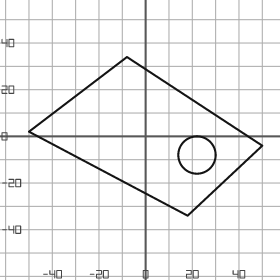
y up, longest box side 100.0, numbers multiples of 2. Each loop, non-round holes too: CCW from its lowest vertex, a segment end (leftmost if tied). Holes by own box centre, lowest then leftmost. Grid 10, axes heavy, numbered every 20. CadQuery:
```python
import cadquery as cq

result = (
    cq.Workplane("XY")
    .moveTo(18.0, -34.0)
    .lineTo(50.0, -4.0)
    .lineTo(-8.0, 34.0)
    .lineTo(-50.0, 2.0)
    .close()
    .moveTo(22.0, -8.0)
    .circle(8.0)
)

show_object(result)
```